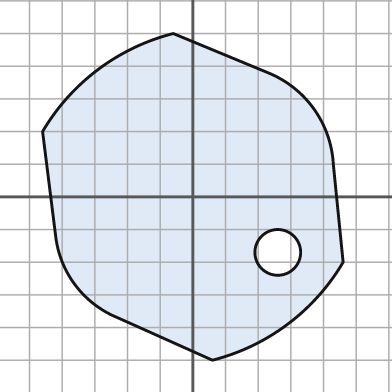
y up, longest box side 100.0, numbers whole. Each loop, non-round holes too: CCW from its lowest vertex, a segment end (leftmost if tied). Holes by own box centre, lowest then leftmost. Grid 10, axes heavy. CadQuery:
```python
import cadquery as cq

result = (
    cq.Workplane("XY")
    .moveTo(6.0, -50.0)
    .threePointArc((29.0, -39.0), (46.0, -20.0))
    .lineTo(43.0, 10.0)
    .threePointArc((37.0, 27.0), (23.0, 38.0))
    .lineTo(-6.0, 50.0)
    .threePointArc((-29.0, 39.0), (-46.0, 20.0))
    .lineTo(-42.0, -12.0)
    .threePointArc((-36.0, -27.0), (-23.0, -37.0))
    .close()
    .moveTo(26.0, -17.0)
    .circle(7.0)
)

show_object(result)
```